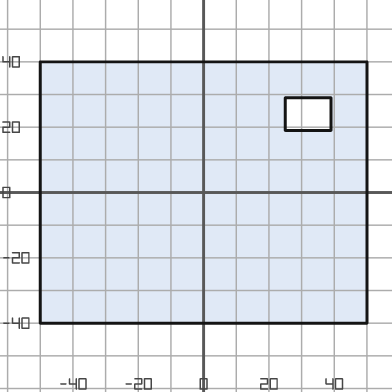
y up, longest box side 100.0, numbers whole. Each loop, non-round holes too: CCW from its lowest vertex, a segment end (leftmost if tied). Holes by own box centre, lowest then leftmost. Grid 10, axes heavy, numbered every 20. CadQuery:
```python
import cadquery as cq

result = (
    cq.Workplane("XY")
    .moveTo(-50.0, -40.0)
    .lineTo(50.0, -40.0)
    .lineTo(50.0, 40.0)
    .lineTo(-50.0, 40.0)
    .close()
    .moveTo(25.0, 19.0)
    .lineTo(39.0, 19.0)
    .lineTo(39.0, 29.0)
    .lineTo(25.0, 29.0)
    .close()
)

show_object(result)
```